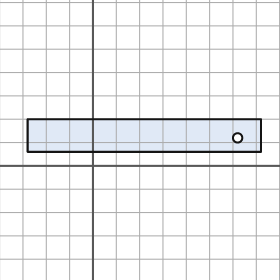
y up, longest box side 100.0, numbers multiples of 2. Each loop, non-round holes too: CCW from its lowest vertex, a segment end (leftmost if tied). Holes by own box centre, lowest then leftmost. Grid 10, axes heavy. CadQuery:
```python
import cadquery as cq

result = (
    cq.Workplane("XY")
    .moveTo(-28.0, 6.0)
    .lineTo(72.0, 6.0)
    .lineTo(72.0, 20.0)
    .lineTo(-28.0, 20.0)
    .close()
    .moveTo(62.0, 12.0)
    .circle(2.0)
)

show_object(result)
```